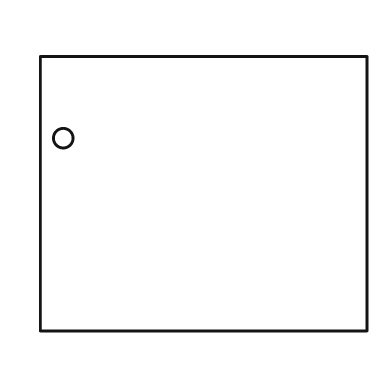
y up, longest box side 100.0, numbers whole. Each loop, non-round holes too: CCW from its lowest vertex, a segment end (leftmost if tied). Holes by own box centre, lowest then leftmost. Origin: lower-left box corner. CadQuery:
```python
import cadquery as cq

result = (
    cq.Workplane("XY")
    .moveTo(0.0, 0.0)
    .lineTo(100.0, 0.0)
    .lineTo(100.0, 84.0)
    .lineTo(0.0, 84.0)
    .close()
    .moveTo(7.0, 59.0)
    .circle(3.0)
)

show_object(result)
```